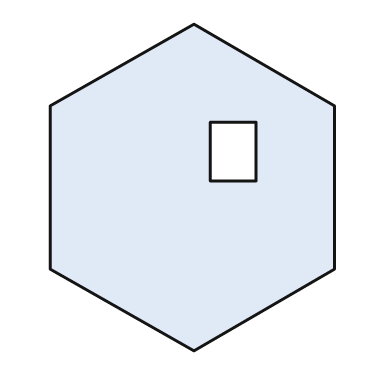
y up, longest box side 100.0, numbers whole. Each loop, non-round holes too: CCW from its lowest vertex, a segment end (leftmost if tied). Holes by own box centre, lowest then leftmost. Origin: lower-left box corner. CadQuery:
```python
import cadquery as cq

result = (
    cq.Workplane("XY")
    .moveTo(44.0, 0.0)
    .lineTo(87.0, 25.0)
    .lineTo(87.0, 75.0)
    .lineTo(44.0, 100.0)
    .lineTo(0.0, 75.0)
    .lineTo(0.0, 25.0)
    .close()
    .moveTo(49.0, 52.0)
    .lineTo(63.0, 52.0)
    .lineTo(63.0, 70.0)
    .lineTo(49.0, 70.0)
    .close()
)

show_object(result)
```